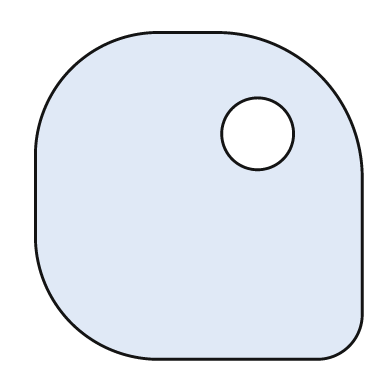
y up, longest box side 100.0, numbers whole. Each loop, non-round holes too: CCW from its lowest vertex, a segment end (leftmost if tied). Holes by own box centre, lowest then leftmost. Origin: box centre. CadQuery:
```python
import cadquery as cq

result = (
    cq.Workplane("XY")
    .moveTo(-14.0, -50.0)
    .lineTo(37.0, -50.0)
    .threePointArc((46.0, -46.0), (50.0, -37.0))
    .lineTo(50.0, 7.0)
    .threePointArc((37.0, 37.0), (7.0, 50.0))
    .lineTo(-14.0, 50.0)
    .threePointArc((-39.0, 39.0), (-50.0, 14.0))
    .lineTo(-50.0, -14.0)
    .threePointArc((-39.0, -39.0), (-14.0, -50.0))
    .close()
    .moveTo(18.0, 19.0)
    .circle(11.0)
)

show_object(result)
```